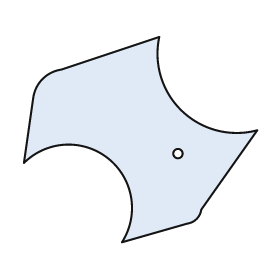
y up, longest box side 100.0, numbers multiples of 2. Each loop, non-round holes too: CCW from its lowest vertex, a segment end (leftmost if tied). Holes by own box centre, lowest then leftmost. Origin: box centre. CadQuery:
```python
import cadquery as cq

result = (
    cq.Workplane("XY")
    .moveTo(-8.0, -44.0)
    .lineTo(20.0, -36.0)
    .threePointArc((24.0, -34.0), (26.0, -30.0))
    .lineTo(50.0, 4.0)
    .threePointArc((18.0, 12.0), (8.0, 44.0))
    .lineTo(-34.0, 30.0)
    .threePointArc((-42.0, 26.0), (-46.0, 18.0))
    .lineTo(-50.0, -10.0)
    .threePointArc((-14.0, -8.0), (-8.0, -44.0))
    .close()
    .moveTo(16.0, -6.0)
    .circle(2.0)
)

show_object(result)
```